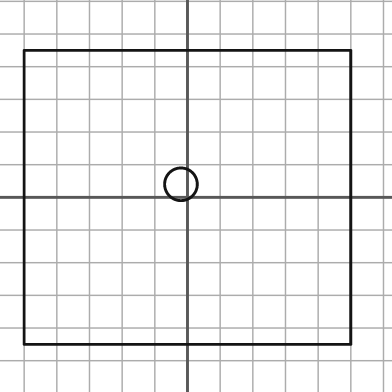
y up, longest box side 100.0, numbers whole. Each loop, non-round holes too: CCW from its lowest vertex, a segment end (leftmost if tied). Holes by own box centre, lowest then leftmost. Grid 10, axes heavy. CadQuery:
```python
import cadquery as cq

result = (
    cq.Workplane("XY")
    .moveTo(-50.0, -45.0)
    .lineTo(50.0, -45.0)
    .lineTo(50.0, 45.0)
    .lineTo(-50.0, 45.0)
    .close()
    .moveTo(-2.0, 4.0)
    .circle(5.0)
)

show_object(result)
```